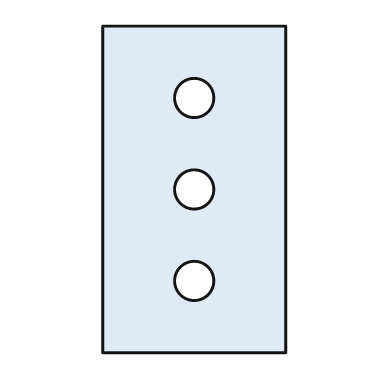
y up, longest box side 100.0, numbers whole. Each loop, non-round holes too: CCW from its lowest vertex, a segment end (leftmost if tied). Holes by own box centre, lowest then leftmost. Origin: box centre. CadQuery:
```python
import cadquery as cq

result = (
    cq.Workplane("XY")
    .moveTo(-28.0, -50.0)
    .lineTo(28.0, -50.0)
    .lineTo(28.0, 50.0)
    .lineTo(-28.0, 50.0)
    .close()
    .moveTo(0.0, -28.0)
    .circle(6.0)
    .moveTo(0.0, 0.0)
    .circle(6.0)
    .moveTo(0.0, 28.0)
    .circle(6.0)
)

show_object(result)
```